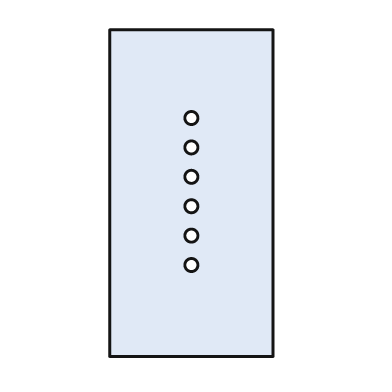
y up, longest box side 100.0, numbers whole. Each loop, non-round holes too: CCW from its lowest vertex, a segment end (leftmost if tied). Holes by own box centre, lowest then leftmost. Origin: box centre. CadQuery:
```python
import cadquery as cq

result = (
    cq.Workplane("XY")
    .moveTo(-25.0, -50.0)
    .lineTo(25.0, -50.0)
    .lineTo(25.0, 50.0)
    .lineTo(-25.0, 50.0)
    .close()
    .moveTo(0.0, -22.0)
    .circle(2.0)
    .moveTo(0.0, -13.0)
    .circle(2.0)
    .moveTo(0.0, -4.0)
    .circle(2.0)
    .moveTo(0.0, 5.0)
    .circle(2.0)
    .moveTo(0.0, 14.0)
    .circle(2.0)
    .moveTo(0.0, 23.0)
    .circle(2.0)
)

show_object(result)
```